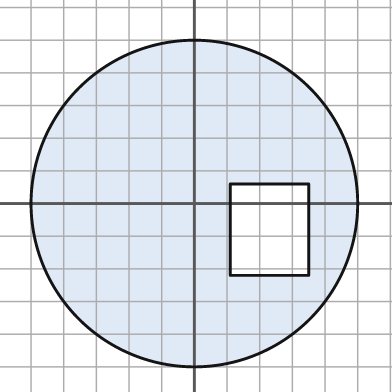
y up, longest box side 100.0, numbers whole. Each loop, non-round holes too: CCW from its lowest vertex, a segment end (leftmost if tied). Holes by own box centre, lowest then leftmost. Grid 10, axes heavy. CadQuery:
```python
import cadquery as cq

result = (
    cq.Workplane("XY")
    .moveTo(0.0, 0.0)
    .circle(50.0)
    .moveTo(11.0, -22.0)
    .lineTo(35.0, -22.0)
    .lineTo(35.0, 6.0)
    .lineTo(11.0, 6.0)
    .close()
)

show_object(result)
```